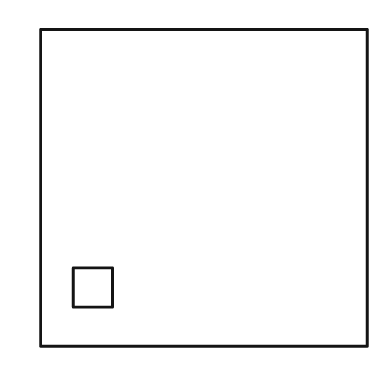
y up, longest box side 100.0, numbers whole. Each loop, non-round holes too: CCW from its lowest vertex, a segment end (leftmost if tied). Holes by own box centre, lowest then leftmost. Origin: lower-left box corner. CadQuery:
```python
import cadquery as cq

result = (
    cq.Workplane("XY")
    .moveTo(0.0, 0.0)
    .lineTo(100.0, 0.0)
    .lineTo(100.0, 97.0)
    .lineTo(0.0, 97.0)
    .close()
    .moveTo(10.0, 12.0)
    .lineTo(22.0, 12.0)
    .lineTo(22.0, 24.0)
    .lineTo(10.0, 24.0)
    .close()
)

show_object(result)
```